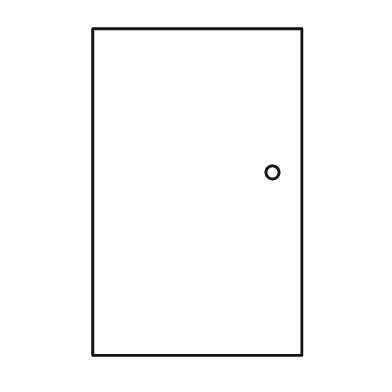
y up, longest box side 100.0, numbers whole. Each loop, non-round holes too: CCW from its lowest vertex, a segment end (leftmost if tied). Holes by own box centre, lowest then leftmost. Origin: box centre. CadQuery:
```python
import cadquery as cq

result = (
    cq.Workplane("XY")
    .moveTo(-32.0, -50.0)
    .lineTo(32.0, -50.0)
    .lineTo(32.0, 50.0)
    .lineTo(-32.0, 50.0)
    .close()
    .moveTo(23.0, 6.0)
    .circle(2.0)
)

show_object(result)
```